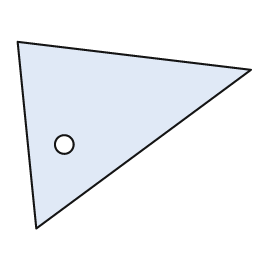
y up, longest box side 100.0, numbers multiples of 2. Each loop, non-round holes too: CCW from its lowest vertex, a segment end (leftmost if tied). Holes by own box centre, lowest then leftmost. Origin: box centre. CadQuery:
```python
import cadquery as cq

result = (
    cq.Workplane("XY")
    .moveTo(-42.0, -40.0)
    .lineTo(50.0, 28.0)
    .lineTo(-50.0, 40.0)
    .close()
    .moveTo(-30.0, -4.0)
    .circle(4.0)
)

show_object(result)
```